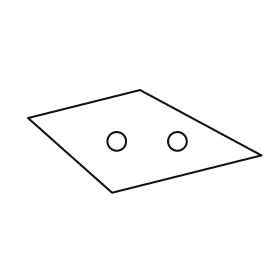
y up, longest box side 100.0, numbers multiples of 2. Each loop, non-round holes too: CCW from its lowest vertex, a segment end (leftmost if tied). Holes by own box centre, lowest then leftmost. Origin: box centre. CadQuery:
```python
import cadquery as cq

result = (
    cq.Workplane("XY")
    .moveTo(-14.0, -22.0)
    .lineTo(50.0, -6.0)
    .lineTo(-2.0, 22.0)
    .lineTo(-50.0, 10.0)
    .close()
    .moveTo(-12.0, 0.0)
    .circle(4.0)
    .moveTo(14.0, 0.0)
    .circle(4.0)
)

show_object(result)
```